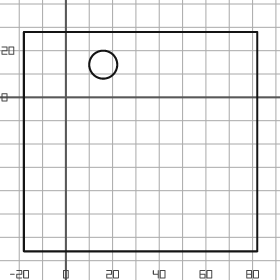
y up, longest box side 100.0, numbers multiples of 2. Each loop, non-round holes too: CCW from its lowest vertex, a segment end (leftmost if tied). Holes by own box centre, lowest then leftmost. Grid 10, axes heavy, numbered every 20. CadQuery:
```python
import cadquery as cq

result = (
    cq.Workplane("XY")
    .moveTo(-18.0, -66.0)
    .lineTo(82.0, -66.0)
    .lineTo(82.0, 28.0)
    .lineTo(-18.0, 28.0)
    .close()
    .moveTo(16.0, 14.0)
    .circle(6.0)
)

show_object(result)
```